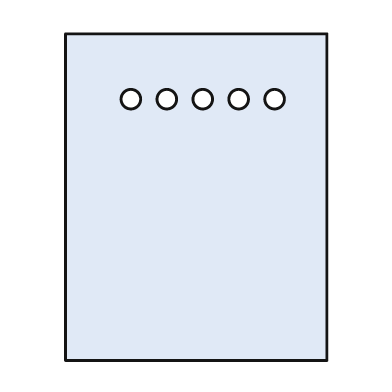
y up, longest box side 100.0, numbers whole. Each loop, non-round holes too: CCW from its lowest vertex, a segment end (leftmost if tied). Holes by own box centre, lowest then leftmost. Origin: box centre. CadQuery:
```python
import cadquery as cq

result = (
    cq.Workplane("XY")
    .moveTo(-40.0, -50.0)
    .lineTo(40.0, -50.0)
    .lineTo(40.0, 50.0)
    .lineTo(-40.0, 50.0)
    .close()
    .moveTo(-20.0, 30.0)
    .circle(3.0)
    .moveTo(-9.0, 30.0)
    .circle(3.0)
    .moveTo(2.0, 30.0)
    .circle(3.0)
    .moveTo(13.0, 30.0)
    .circle(3.0)
    .moveTo(24.0, 30.0)
    .circle(3.0)
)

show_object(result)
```